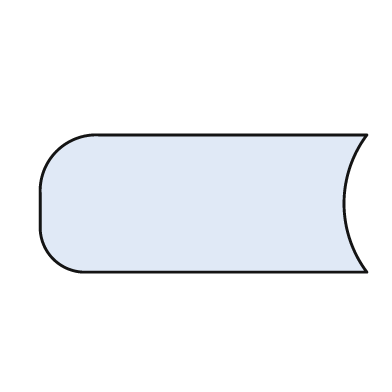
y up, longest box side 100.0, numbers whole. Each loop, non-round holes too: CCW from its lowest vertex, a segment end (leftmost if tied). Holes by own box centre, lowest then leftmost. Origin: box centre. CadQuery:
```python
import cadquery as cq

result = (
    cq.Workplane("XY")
    .moveTo(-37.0, -21.0)
    .lineTo(50.0, -21.0)
    .threePointArc((43.0, 0.0), (50.0, 21.0))
    .lineTo(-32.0, 21.0)
    .threePointArc((-45.0, 16.0), (-50.0, 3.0))
    .lineTo(-50.0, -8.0)
    .threePointArc((-46.0, -17.0), (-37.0, -21.0))
    .close()
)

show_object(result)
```